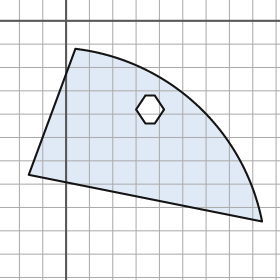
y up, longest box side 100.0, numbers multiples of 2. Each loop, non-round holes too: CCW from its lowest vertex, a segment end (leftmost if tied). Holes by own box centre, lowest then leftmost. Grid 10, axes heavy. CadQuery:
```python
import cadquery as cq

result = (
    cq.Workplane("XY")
    .moveTo(84.0, -86.0)
    .threePointArc((56.0, -36.0), (4.0, -12.0))
    .lineTo(-16.0, -66.0)
    .close()
    .moveTo(34.0, -44.0)
    .lineTo(38.0, -44.0)
    .lineTo(42.0, -38.0)
    .lineTo(38.0, -32.0)
    .lineTo(34.0, -32.0)
    .lineTo(30.0, -38.0)
    .close()
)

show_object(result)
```